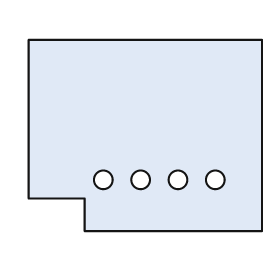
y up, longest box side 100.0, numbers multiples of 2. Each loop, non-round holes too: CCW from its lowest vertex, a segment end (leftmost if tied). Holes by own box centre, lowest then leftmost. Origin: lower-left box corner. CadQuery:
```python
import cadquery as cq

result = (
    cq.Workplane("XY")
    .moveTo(24.0, 0.0)
    .lineTo(100.0, 0.0)
    .lineTo(100.0, 82.0)
    .lineTo(0.0, 82.0)
    .lineTo(0.0, 14.0)
    .lineTo(24.0, 14.0)
    .close()
    .moveTo(32.0, 22.0)
    .circle(4.0)
    .moveTo(48.0, 22.0)
    .circle(4.0)
    .moveTo(64.0, 22.0)
    .circle(4.0)
    .moveTo(80.0, 22.0)
    .circle(4.0)
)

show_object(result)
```